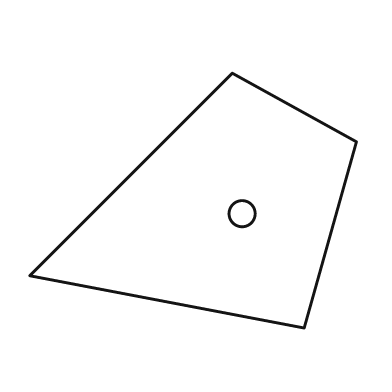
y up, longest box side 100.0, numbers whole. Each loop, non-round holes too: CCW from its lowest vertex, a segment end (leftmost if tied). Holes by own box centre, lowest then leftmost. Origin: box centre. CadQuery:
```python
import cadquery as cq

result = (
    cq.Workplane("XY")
    .moveTo(34.0, -39.0)
    .lineTo(50.0, 18.0)
    .lineTo(12.0, 39.0)
    .lineTo(-50.0, -23.0)
    .close()
    .moveTo(15.0, -4.0)
    .circle(4.0)
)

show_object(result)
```